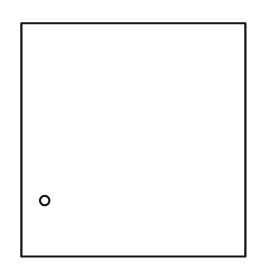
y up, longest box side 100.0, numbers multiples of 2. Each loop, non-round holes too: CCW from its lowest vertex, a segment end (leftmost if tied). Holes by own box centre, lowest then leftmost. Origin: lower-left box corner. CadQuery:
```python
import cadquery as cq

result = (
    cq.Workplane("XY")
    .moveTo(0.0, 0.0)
    .lineTo(96.0, 0.0)
    .lineTo(96.0, 100.0)
    .lineTo(0.0, 100.0)
    .close()
    .moveTo(10.0, 24.0)
    .circle(2.0)
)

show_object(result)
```